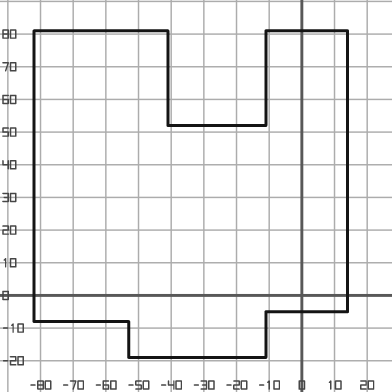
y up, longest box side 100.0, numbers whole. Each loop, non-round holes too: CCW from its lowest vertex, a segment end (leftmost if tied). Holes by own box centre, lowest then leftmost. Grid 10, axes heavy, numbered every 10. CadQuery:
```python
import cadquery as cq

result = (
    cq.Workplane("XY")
    .moveTo(-53.0, -19.0)
    .lineTo(-11.0, -19.0)
    .lineTo(-11.0, -5.0)
    .lineTo(14.0, -5.0)
    .lineTo(14.0, 81.0)
    .lineTo(-11.0, 81.0)
    .lineTo(-11.0, 52.0)
    .lineTo(-41.0, 52.0)
    .lineTo(-41.0, 81.0)
    .lineTo(-82.0, 81.0)
    .lineTo(-82.0, -8.0)
    .lineTo(-53.0, -8.0)
    .close()
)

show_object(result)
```